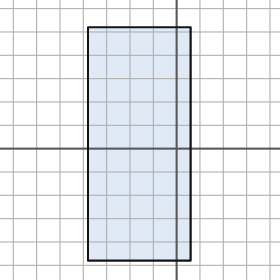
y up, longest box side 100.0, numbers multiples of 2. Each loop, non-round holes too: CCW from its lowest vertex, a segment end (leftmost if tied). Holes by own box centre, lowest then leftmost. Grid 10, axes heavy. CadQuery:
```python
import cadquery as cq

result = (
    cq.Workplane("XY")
    .moveTo(-38.0, -48.0)
    .lineTo(6.0, -48.0)
    .lineTo(6.0, 52.0)
    .lineTo(-38.0, 52.0)
    .close()
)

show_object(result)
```